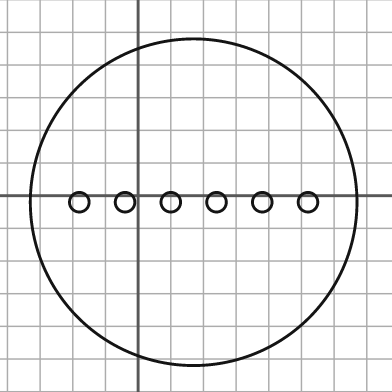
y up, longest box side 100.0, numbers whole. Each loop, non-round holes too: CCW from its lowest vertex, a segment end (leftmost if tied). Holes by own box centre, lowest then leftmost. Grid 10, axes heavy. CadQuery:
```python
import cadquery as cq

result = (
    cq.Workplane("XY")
    .moveTo(17.0, -2.0)
    .circle(50.0)
    .moveTo(-18.0, -2.0)
    .circle(3.0)
    .moveTo(-4.0, -2.0)
    .circle(3.0)
    .moveTo(10.0, -2.0)
    .circle(3.0)
    .moveTo(24.0, -2.0)
    .circle(3.0)
    .moveTo(38.0, -2.0)
    .circle(3.0)
    .moveTo(52.0, -2.0)
    .circle(3.0)
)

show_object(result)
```